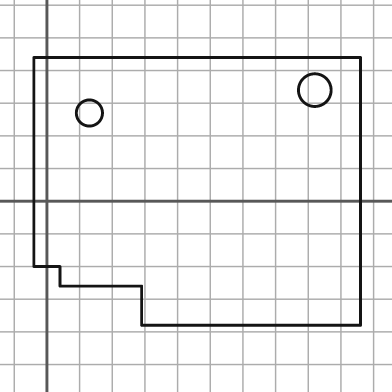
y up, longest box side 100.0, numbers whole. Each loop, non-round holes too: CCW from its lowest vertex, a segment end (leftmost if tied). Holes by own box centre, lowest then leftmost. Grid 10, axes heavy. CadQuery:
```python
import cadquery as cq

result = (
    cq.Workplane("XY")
    .moveTo(29.0, -38.0)
    .lineTo(96.0, -38.0)
    .lineTo(96.0, 44.0)
    .lineTo(-4.0, 44.0)
    .lineTo(-4.0, -20.0)
    .lineTo(4.0, -20.0)
    .lineTo(4.0, -26.0)
    .lineTo(29.0, -26.0)
    .close()
    .moveTo(13.0, 27.0)
    .circle(4.0)
    .moveTo(82.0, 34.0)
    .circle(5.0)
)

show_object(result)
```